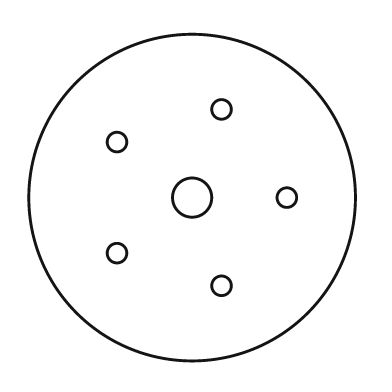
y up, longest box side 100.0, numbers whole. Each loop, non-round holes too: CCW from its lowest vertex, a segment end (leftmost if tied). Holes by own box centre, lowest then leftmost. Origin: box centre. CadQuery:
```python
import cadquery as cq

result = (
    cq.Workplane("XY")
    .moveTo(0.0, 0.0)
    .circle(50.0)
    .moveTo(9.0, -27.0)
    .circle(3.0)
    .moveTo(-23.0, -17.0)
    .circle(3.0)
    .moveTo(0.0, 0.0)
    .circle(6.0)
    .moveTo(29.0, 0.0)
    .circle(3.0)
    .moveTo(-23.0, 17.0)
    .circle(3.0)
    .moveTo(9.0, 27.0)
    .circle(3.0)
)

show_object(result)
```